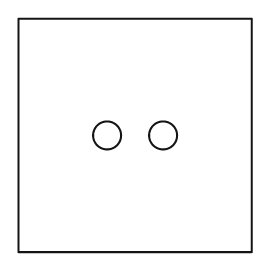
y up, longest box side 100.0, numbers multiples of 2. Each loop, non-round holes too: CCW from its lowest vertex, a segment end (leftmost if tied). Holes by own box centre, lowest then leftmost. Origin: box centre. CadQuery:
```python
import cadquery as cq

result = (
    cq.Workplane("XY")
    .moveTo(-50.0, -50.0)
    .lineTo(50.0, -50.0)
    .lineTo(50.0, 50.0)
    .lineTo(-50.0, 50.0)
    .close()
    .moveTo(-12.0, 0.0)
    .circle(6.0)
    .moveTo(12.0, 0.0)
    .circle(6.0)
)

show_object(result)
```